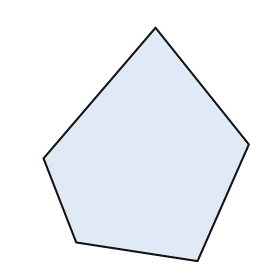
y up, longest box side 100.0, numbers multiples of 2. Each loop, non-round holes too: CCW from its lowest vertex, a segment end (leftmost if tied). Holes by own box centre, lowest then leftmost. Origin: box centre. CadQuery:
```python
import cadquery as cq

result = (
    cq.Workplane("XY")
    .moveTo(22.0, -50.0)
    .lineTo(44.0, 0.0)
    .lineTo(4.0, 50.0)
    .lineTo(-44.0, -6.0)
    .lineTo(-30.0, -42.0)
    .close()
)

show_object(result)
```